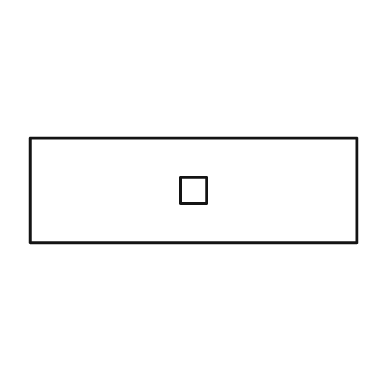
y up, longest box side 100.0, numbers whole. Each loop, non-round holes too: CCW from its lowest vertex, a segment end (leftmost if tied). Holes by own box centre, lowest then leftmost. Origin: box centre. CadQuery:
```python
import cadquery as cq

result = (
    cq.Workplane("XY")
    .moveTo(-50.0, -16.0)
    .lineTo(50.0, -16.0)
    .lineTo(50.0, 16.0)
    .lineTo(-50.0, 16.0)
    .close()
    .moveTo(-4.0, -4.0)
    .lineTo(4.0, -4.0)
    .lineTo(4.0, 4.0)
    .lineTo(-4.0, 4.0)
    .close()
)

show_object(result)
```